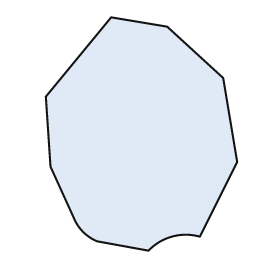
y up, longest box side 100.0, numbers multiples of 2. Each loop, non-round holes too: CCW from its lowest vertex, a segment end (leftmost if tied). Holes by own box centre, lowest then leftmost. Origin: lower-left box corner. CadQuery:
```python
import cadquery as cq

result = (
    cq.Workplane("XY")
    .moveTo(44.0, 0.0)
    .threePointArc((54.0, 6.0), (66.0, 6.0))
    .lineTo(82.0, 38.0)
    .lineTo(76.0, 74.0)
    .lineTo(52.0, 96.0)
    .lineTo(28.0, 100.0)
    .lineTo(0.0, 66.0)
    .lineTo(2.0, 36.0)
    .lineTo(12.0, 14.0)
    .threePointArc((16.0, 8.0), (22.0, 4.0))
    .close()
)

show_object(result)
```